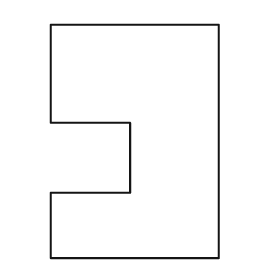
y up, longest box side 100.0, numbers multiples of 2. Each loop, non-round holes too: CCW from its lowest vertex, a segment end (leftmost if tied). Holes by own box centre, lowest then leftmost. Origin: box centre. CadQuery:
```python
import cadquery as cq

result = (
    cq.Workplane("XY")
    .moveTo(-36.0, -50.0)
    .lineTo(36.0, -50.0)
    .lineTo(36.0, 50.0)
    .lineTo(-36.0, 50.0)
    .lineTo(-36.0, 8.0)
    .lineTo(-2.0, 8.0)
    .lineTo(-2.0, -22.0)
    .lineTo(-36.0, -22.0)
    .close()
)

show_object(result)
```